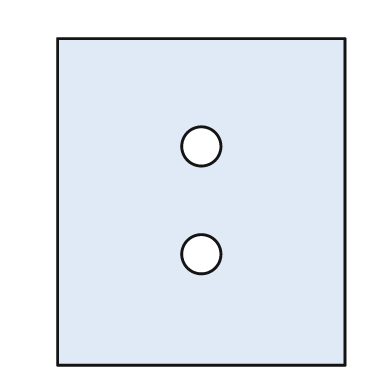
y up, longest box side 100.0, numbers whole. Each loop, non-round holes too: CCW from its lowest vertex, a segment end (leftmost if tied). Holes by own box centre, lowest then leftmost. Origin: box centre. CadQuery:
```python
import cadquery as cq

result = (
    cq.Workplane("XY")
    .moveTo(-44.0, -50.0)
    .lineTo(44.0, -50.0)
    .lineTo(44.0, 50.0)
    .lineTo(-44.0, 50.0)
    .close()
    .moveTo(0.0, -16.0)
    .circle(6.0)
    .moveTo(0.0, 17.0)
    .circle(6.0)
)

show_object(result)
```